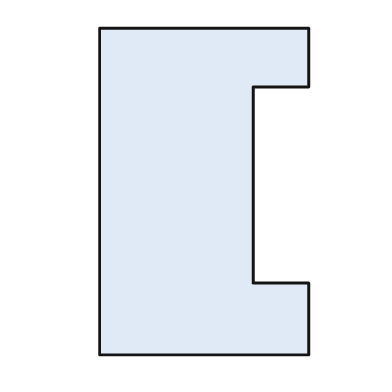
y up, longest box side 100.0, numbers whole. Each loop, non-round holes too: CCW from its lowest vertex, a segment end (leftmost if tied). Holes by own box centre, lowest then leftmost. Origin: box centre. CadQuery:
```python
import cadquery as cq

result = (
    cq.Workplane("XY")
    .moveTo(-32.0, -50.0)
    .lineTo(32.0, -50.0)
    .lineTo(32.0, -28.0)
    .lineTo(15.0, -28.0)
    .lineTo(15.0, 32.0)
    .lineTo(32.0, 32.0)
    .lineTo(32.0, 50.0)
    .lineTo(-32.0, 50.0)
    .close()
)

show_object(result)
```